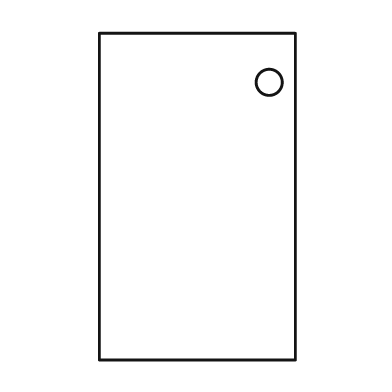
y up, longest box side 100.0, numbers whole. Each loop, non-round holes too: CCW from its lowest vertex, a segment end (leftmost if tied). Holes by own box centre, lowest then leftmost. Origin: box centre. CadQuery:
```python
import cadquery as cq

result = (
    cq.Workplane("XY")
    .moveTo(-30.0, -50.0)
    .lineTo(30.0, -50.0)
    .lineTo(30.0, 50.0)
    .lineTo(-30.0, 50.0)
    .close()
    .moveTo(22.0, 35.0)
    .circle(4.0)
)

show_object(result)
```